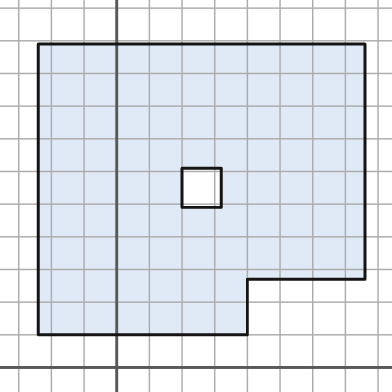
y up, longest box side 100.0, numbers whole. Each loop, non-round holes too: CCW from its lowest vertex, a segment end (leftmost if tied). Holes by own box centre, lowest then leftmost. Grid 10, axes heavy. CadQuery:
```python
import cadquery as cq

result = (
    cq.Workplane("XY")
    .moveTo(-24.0, 10.0)
    .lineTo(40.0, 10.0)
    .lineTo(40.0, 27.0)
    .lineTo(76.0, 27.0)
    .lineTo(76.0, 99.0)
    .lineTo(-24.0, 99.0)
    .close()
    .moveTo(20.0, 49.0)
    .lineTo(32.0, 49.0)
    .lineTo(32.0, 61.0)
    .lineTo(20.0, 61.0)
    .close()
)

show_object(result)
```